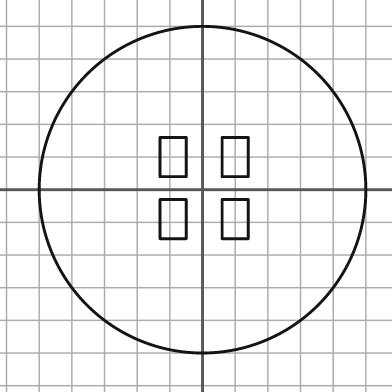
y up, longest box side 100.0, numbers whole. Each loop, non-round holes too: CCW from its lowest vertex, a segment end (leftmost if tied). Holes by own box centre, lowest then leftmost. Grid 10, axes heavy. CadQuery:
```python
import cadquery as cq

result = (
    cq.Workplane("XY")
    .moveTo(0.0, 0.0)
    .circle(50.0)
    .moveTo(-13.0, -15.0)
    .lineTo(-5.0, -15.0)
    .lineTo(-5.0, -3.0)
    .lineTo(-13.0, -3.0)
    .close()
    .moveTo(6.0, -15.0)
    .lineTo(14.0, -15.0)
    .lineTo(14.0, -3.0)
    .lineTo(6.0, -3.0)
    .close()
    .moveTo(-13.0, 4.0)
    .lineTo(-5.0, 4.0)
    .lineTo(-5.0, 16.0)
    .lineTo(-13.0, 16.0)
    .close()
    .moveTo(6.0, 4.0)
    .lineTo(14.0, 4.0)
    .lineTo(14.0, 16.0)
    .lineTo(6.0, 16.0)
    .close()
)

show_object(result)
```